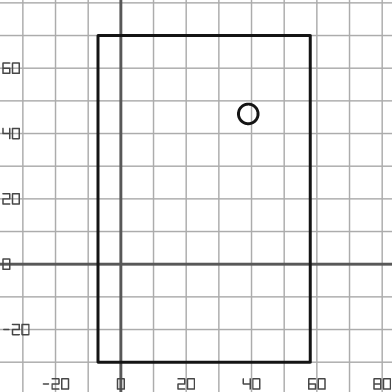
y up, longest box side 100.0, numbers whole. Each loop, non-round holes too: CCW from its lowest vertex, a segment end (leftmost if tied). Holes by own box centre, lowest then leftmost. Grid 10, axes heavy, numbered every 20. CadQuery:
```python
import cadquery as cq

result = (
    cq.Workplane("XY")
    .moveTo(-7.0, -30.0)
    .lineTo(58.0, -30.0)
    .lineTo(58.0, 70.0)
    .lineTo(-7.0, 70.0)
    .close()
    .moveTo(39.0, 46.0)
    .circle(3.0)
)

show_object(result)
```